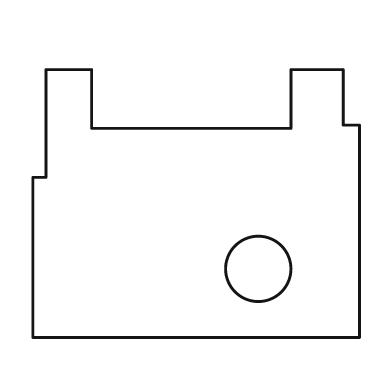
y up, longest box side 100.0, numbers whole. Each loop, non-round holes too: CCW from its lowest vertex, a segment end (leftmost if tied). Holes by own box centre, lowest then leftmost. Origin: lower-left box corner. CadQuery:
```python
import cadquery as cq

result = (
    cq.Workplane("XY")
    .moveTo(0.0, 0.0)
    .lineTo(100.0, 0.0)
    .lineTo(100.0, 65.0)
    .lineTo(95.0, 65.0)
    .lineTo(95.0, 82.0)
    .lineTo(79.0, 82.0)
    .lineTo(79.0, 64.0)
    .lineTo(18.0, 64.0)
    .lineTo(18.0, 82.0)
    .lineTo(4.0, 82.0)
    .lineTo(4.0, 49.0)
    .lineTo(0.0, 49.0)
    .close()
    .moveTo(69.0, 21.0)
    .circle(10.0)
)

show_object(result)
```